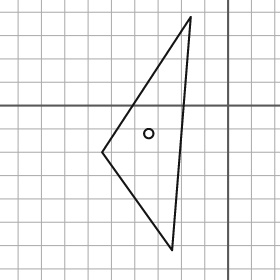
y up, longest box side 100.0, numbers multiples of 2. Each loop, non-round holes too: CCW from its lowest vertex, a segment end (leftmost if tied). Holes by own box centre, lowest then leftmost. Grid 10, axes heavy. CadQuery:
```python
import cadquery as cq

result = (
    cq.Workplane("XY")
    .moveTo(-24.0, -62.0)
    .lineTo(-16.0, 38.0)
    .lineTo(-54.0, -20.0)
    .close()
    .moveTo(-34.0, -12.0)
    .circle(2.0)
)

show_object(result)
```